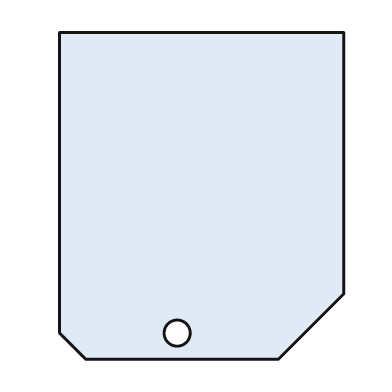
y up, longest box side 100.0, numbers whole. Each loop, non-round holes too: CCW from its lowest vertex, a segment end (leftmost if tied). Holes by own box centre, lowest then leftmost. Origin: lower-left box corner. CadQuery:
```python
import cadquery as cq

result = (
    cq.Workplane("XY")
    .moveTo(8.0, 0.0)
    .lineTo(67.0, 0.0)
    .lineTo(87.0, 20.0)
    .lineTo(87.0, 100.0)
    .lineTo(0.0, 100.0)
    .lineTo(0.0, 8.0)
    .close()
    .moveTo(36.0, 8.0)
    .circle(4.0)
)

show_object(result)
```